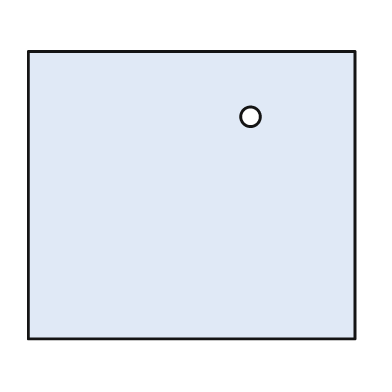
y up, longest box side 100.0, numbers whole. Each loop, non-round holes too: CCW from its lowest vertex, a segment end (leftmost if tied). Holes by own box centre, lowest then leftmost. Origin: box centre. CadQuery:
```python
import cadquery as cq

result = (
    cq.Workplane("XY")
    .moveTo(-50.0, -44.0)
    .lineTo(50.0, -44.0)
    .lineTo(50.0, 44.0)
    .lineTo(-50.0, 44.0)
    .close()
    .moveTo(18.0, 24.0)
    .circle(3.0)
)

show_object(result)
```